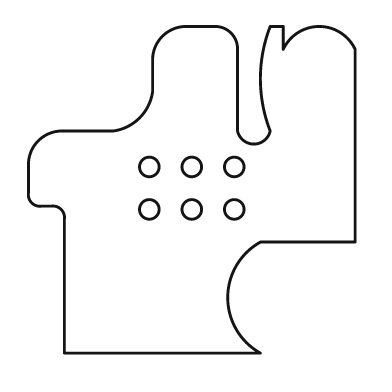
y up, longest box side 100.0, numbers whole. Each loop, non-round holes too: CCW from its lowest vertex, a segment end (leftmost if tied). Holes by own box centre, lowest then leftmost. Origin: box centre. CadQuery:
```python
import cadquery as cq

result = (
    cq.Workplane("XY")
    .moveTo(-39.0, -50.0)
    .lineTo(21.0, -50.0)
    .threePointArc((11.0, -33.0), (21.0, -16.0))
    .lineTo(50.0, -16.0)
    .lineTo(50.0, 43.0)
    .threePointArc((39.0, 50.0), (28.0, 43.0))
    .lineTo(28.0, 50.0)
    .lineTo(24.0, 50.0)
    .threePointArc((21.0, 34.0), (24.0, 18.0))
    .threePointArc((19.0, 14.0), (14.0, 18.0))
    .lineTo(14.0, 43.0)
    .threePointArc((12.0, 48.0), (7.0, 50.0))
    .lineTo(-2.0, 50.0)
    .threePointArc((-9.0, 47.0), (-12.0, 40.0))
    .lineTo(-12.0, 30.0)
    .threePointArc((-16.0, 22.0), (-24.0, 18.0))
    .lineTo(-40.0, 18.0)
    .threePointArc((-47.0, 15.0), (-50.0, 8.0))
    .lineTo(-50.0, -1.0)
    .threePointArc((-49.0, -4.0), (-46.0, -5.0))
    .lineTo(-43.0, -5.0)
    .threePointArc((-40.0, -6.0), (-39.0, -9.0))
    .close()
    .moveTo(-13.0, -6.0)
    .circle(3.0)
    .moveTo(0.0, -6.0)
    .circle(3.0)
    .moveTo(13.0, -6.0)
    .circle(3.0)
    .moveTo(-13.0, 7.0)
    .circle(3.0)
    .moveTo(0.0, 7.0)
    .circle(3.0)
    .moveTo(13.0, 7.0)
    .circle(3.0)
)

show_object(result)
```